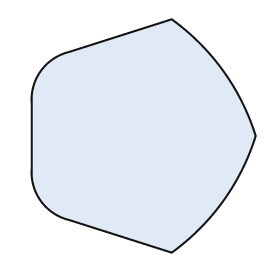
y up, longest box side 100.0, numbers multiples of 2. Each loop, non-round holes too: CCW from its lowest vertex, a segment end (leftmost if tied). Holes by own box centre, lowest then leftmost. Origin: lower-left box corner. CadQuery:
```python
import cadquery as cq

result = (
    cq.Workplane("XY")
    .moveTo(60.0, 0.0)
    .threePointArc((82.0, 22.0), (96.0, 50.0))
    .threePointArc((82.0, 78.0), (60.0, 100.0))
    .lineTo(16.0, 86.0)
    .threePointArc((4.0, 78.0), (0.0, 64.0))
    .lineTo(0.0, 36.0)
    .threePointArc((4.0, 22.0), (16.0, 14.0))
    .close()
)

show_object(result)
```